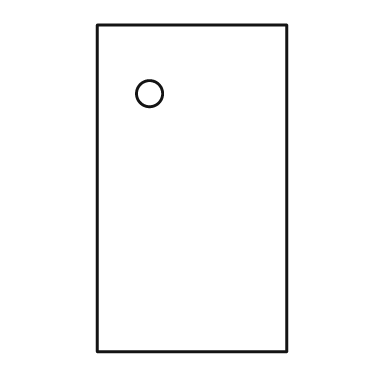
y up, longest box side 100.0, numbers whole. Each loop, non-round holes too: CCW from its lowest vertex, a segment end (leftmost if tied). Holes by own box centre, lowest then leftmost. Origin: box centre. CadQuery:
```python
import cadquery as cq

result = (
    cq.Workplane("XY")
    .moveTo(-29.0, -50.0)
    .lineTo(29.0, -50.0)
    .lineTo(29.0, 50.0)
    .lineTo(-29.0, 50.0)
    .close()
    .moveTo(-13.0, 29.0)
    .circle(4.0)
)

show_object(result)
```